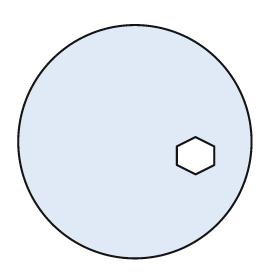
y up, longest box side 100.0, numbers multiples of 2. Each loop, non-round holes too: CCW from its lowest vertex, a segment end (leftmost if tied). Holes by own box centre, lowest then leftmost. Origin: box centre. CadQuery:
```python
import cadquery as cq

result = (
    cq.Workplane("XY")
    .moveTo(0.0, 0.0)
    .circle(50.0)
    .moveTo(26.0, -14.0)
    .lineTo(34.0, -10.0)
    .lineTo(34.0, -2.0)
    .lineTo(26.0, 2.0)
    .lineTo(18.0, -2.0)
    .lineTo(18.0, -10.0)
    .close()
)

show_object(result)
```